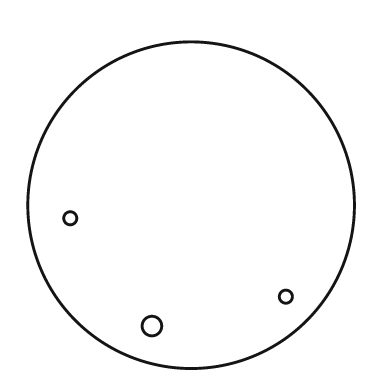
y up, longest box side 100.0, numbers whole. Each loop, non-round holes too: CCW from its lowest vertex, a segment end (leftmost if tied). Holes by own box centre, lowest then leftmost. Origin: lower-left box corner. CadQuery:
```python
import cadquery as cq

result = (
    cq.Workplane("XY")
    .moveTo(50.0, 50.0)
    .circle(50.0)
    .moveTo(38.0, 13.0)
    .circle(3.0)
    .moveTo(79.0, 22.0)
    .circle(2.0)
    .moveTo(13.0, 46.0)
    .circle(2.0)
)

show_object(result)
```